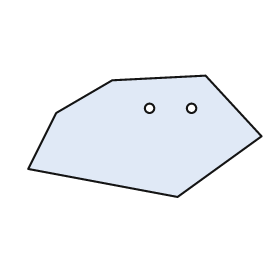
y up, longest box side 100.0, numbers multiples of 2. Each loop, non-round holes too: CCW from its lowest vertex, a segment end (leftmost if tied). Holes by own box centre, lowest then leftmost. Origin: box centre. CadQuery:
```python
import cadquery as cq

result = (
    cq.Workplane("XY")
    .moveTo(14.0, -26.0)
    .lineTo(50.0, 0.0)
    .lineTo(26.0, 26.0)
    .lineTo(-14.0, 24.0)
    .lineTo(-38.0, 10.0)
    .lineTo(-50.0, -14.0)
    .close()
    .moveTo(2.0, 12.0)
    .circle(2.0)
    .moveTo(20.0, 12.0)
    .circle(2.0)
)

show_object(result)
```